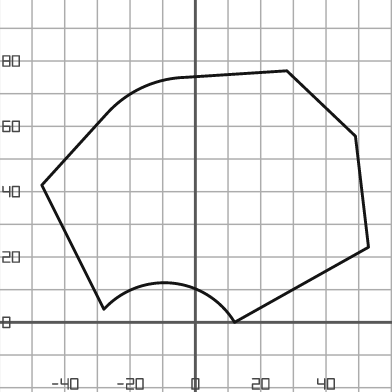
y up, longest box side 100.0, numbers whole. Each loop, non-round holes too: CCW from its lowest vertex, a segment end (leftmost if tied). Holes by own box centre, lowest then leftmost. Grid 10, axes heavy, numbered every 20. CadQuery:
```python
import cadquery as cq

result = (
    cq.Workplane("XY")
    .moveTo(12.0, 0.0)
    .lineTo(53.0, 23.0)
    .lineTo(49.0, 57.0)
    .lineTo(28.0, 77.0)
    .lineTo(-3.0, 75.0)
    .threePointArc((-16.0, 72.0), (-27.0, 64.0))
    .lineTo(-47.0, 42.0)
    .lineTo(-28.0, 4.0)
    .threePointArc((-7.0, 12.0), (12.0, 0.0))
    .close()
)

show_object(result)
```